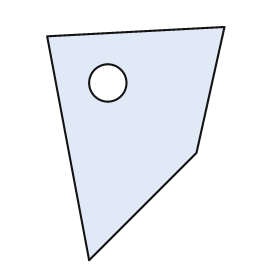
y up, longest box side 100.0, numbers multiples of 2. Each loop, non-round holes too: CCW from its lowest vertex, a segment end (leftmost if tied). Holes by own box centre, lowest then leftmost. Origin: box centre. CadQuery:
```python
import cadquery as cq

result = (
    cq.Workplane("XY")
    .moveTo(-20.0, -50.0)
    .lineTo(26.0, -4.0)
    .lineTo(38.0, 50.0)
    .lineTo(-38.0, 46.0)
    .close()
    .moveTo(-12.0, 26.0)
    .circle(8.0)
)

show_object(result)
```